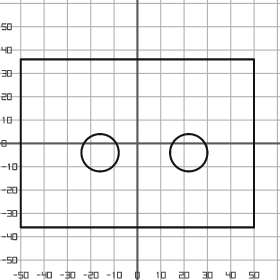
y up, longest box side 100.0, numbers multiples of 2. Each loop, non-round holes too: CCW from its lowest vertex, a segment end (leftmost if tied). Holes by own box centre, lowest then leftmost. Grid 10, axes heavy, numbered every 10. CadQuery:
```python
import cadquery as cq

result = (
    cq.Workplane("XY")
    .moveTo(-50.0, -36.0)
    .lineTo(50.0, -36.0)
    .lineTo(50.0, 36.0)
    .lineTo(-50.0, 36.0)
    .close()
    .moveTo(-16.0, -4.0)
    .circle(8.0)
    .moveTo(22.0, -4.0)
    .circle(8.0)
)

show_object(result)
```